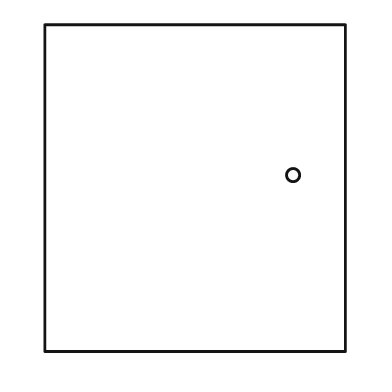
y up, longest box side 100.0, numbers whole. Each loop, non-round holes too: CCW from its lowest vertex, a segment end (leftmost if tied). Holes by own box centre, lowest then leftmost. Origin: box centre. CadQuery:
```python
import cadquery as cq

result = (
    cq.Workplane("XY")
    .moveTo(-46.0, -50.0)
    .lineTo(46.0, -50.0)
    .lineTo(46.0, 50.0)
    .lineTo(-46.0, 50.0)
    .close()
    .moveTo(30.0, 4.0)
    .circle(2.0)
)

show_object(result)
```